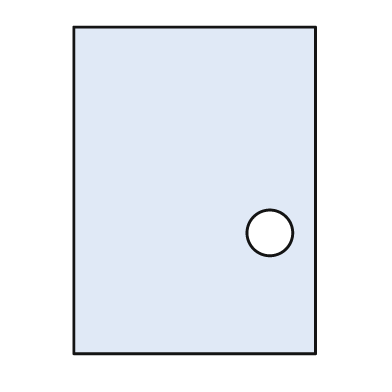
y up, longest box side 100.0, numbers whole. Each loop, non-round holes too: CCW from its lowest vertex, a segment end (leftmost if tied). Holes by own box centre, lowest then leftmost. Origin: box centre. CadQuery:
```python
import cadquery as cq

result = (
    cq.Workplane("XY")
    .moveTo(-37.0, -50.0)
    .lineTo(37.0, -50.0)
    .lineTo(37.0, 50.0)
    .lineTo(-37.0, 50.0)
    .close()
    .moveTo(23.0, -13.0)
    .circle(7.0)
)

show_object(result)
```